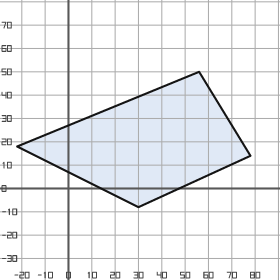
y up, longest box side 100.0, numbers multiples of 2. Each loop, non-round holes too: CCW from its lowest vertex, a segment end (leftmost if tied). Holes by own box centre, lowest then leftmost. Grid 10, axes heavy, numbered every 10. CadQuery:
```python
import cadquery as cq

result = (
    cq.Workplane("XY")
    .moveTo(30.0, -8.0)
    .lineTo(78.0, 14.0)
    .lineTo(56.0, 50.0)
    .lineTo(-22.0, 18.0)
    .close()
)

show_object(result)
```